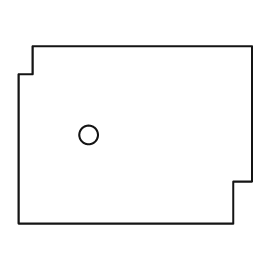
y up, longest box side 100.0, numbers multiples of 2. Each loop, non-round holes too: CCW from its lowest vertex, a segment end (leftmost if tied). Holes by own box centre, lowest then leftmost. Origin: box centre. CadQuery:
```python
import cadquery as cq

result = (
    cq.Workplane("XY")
    .moveTo(-50.0, -38.0)
    .lineTo(42.0, -38.0)
    .lineTo(42.0, -20.0)
    .lineTo(50.0, -20.0)
    .lineTo(50.0, 38.0)
    .lineTo(-44.0, 38.0)
    .lineTo(-44.0, 26.0)
    .lineTo(-50.0, 26.0)
    .close()
    .moveTo(-20.0, 0.0)
    .circle(4.0)
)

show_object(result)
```